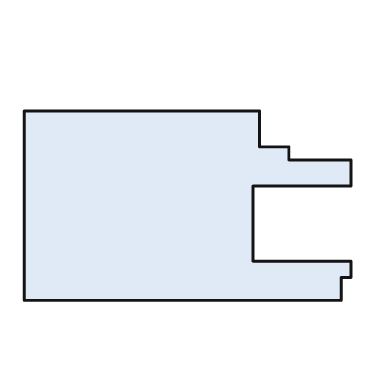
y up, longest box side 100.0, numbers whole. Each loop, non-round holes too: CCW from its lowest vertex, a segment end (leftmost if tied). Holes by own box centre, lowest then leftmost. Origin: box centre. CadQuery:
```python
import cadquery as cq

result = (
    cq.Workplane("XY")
    .moveTo(-50.0, -29.0)
    .lineTo(47.0, -29.0)
    .lineTo(47.0, -22.0)
    .lineTo(50.0, -22.0)
    .lineTo(50.0, -17.0)
    .lineTo(20.0, -17.0)
    .lineTo(20.0, 6.0)
    .lineTo(50.0, 6.0)
    .lineTo(50.0, 14.0)
    .lineTo(31.0, 14.0)
    .lineTo(31.0, 18.0)
    .lineTo(22.0, 18.0)
    .lineTo(22.0, 29.0)
    .lineTo(-50.0, 29.0)
    .close()
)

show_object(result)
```